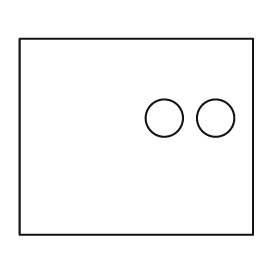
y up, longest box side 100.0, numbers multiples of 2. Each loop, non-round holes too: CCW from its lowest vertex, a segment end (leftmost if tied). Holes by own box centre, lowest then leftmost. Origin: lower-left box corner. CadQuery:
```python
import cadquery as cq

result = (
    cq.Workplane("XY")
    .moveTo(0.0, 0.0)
    .lineTo(100.0, 0.0)
    .lineTo(100.0, 84.0)
    .lineTo(0.0, 84.0)
    .close()
    .moveTo(62.0, 50.0)
    .circle(8.0)
    .moveTo(84.0, 50.0)
    .circle(8.0)
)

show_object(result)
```